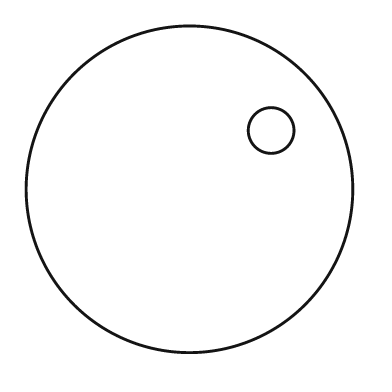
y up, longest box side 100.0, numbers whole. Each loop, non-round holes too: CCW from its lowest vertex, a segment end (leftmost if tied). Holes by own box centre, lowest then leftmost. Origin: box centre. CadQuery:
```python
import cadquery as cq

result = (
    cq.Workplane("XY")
    .moveTo(0.0, 0.0)
    .circle(50.0)
    .moveTo(25.0, 18.0)
    .circle(7.0)
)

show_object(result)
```